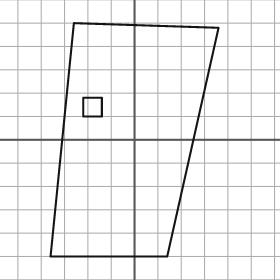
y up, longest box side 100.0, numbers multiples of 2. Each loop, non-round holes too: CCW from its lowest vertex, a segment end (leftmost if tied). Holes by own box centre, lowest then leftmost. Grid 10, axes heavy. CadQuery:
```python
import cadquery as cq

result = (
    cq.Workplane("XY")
    .moveTo(-36.0, -50.0)
    .lineTo(14.0, -50.0)
    .lineTo(36.0, 48.0)
    .lineTo(-26.0, 50.0)
    .close()
    .moveTo(-22.0, 10.0)
    .lineTo(-14.0, 10.0)
    .lineTo(-14.0, 18.0)
    .lineTo(-22.0, 18.0)
    .close()
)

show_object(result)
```